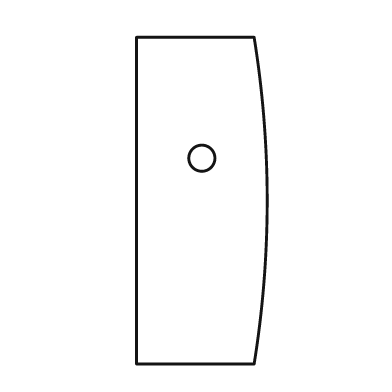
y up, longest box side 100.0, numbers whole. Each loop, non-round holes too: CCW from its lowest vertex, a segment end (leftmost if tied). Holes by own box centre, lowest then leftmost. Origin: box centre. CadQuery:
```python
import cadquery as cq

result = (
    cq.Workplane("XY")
    .moveTo(-20.0, -50.0)
    .lineTo(16.0, -50.0)
    .threePointArc((20.0, 0.0), (16.0, 50.0))
    .lineTo(-20.0, 50.0)
    .close()
    .moveTo(0.0, 13.0)
    .circle(4.0)
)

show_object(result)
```